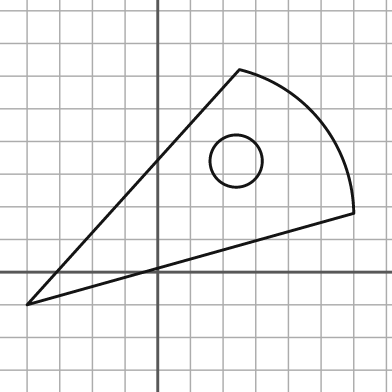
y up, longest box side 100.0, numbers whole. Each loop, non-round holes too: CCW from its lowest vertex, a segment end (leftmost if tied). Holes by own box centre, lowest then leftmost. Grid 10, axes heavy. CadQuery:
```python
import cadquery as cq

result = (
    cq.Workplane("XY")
    .moveTo(-40.0, -10.0)
    .lineTo(60.0, 18.0)
    .threePointArc((50.0, 46.0), (25.0, 62.0))
    .close()
    .moveTo(24.0, 34.0)
    .circle(8.0)
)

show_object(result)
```